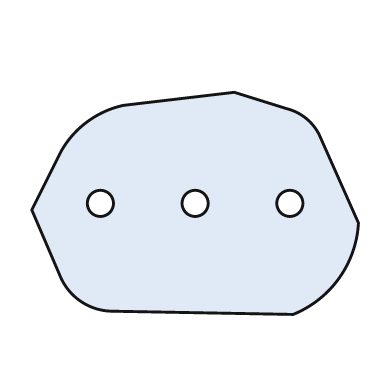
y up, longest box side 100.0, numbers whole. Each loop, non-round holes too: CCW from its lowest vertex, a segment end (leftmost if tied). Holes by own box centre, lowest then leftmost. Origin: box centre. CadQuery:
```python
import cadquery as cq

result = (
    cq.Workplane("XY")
    .moveTo(30.0, -34.0)
    .threePointArc((44.0, -23.0), (50.0, -6.0))
    .lineTo(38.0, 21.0)
    .threePointArc((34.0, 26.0), (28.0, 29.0))
    .lineTo(12.0, 34.0)
    .lineTo(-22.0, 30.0)
    .threePointArc((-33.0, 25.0), (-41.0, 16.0))
    .lineTo(-50.0, -2.0)
    .lineTo(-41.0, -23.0)
    .threePointArc((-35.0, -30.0), (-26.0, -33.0))
    .close()
    .moveTo(-29.0, 0.0)
    .circle(4.0)
    .moveTo(0.0, 0.0)
    .circle(4.0)
    .moveTo(29.0, 0.0)
    .circle(4.0)
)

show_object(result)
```